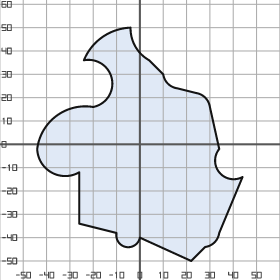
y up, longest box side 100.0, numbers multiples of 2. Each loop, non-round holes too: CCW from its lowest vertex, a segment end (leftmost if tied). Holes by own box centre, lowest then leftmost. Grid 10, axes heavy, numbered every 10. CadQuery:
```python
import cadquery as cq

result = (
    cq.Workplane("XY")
    .moveTo(22.0, -50.0)
    .lineTo(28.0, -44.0)
    .threePointArc((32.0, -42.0), (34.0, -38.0))
    .lineTo(44.0, -14.0)
    .threePointArc((34.0, -12.0), (34.0, -2.0))
    .lineTo(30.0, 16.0)
    .threePointArc((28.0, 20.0), (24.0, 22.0))
    .lineTo(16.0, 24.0)
    .threePointArc((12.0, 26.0), (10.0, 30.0))
    .lineTo(4.0, 36.0)
    .threePointArc((-2.0, 42.0), (-4.0, 50.0))
    .threePointArc((-16.0, 46.0), (-24.0, 36.0))
    .threePointArc((-12.0, 28.0), (-20.0, 16.0))
    .threePointArc((-36.0, 12.0), (-44.0, -2.0))
    .threePointArc((-38.0, -12.0), (-26.0, -12.0))
    .lineTo(-26.0, -34.0)
    .lineTo(-10.0, -38.0)
    .threePointArc((-6.0, -44.0), (0.0, -40.0))
    .close()
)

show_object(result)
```